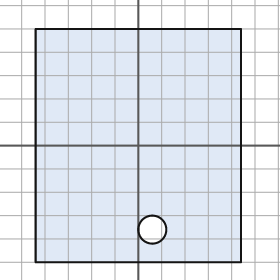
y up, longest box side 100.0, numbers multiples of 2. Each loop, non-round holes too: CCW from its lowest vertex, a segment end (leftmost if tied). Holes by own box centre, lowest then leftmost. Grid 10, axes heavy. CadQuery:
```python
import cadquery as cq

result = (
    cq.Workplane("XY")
    .moveTo(-44.0, -50.0)
    .lineTo(44.0, -50.0)
    .lineTo(44.0, 50.0)
    .lineTo(-44.0, 50.0)
    .close()
    .moveTo(6.0, -36.0)
    .circle(6.0)
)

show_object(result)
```